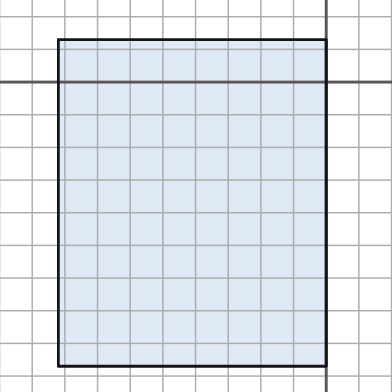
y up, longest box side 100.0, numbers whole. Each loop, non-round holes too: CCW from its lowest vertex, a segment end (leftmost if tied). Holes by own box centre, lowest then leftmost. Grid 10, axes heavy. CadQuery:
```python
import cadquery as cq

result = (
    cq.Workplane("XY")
    .moveTo(-82.0, -87.0)
    .lineTo(0.0, -87.0)
    .lineTo(0.0, 13.0)
    .lineTo(-82.0, 13.0)
    .close()
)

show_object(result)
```